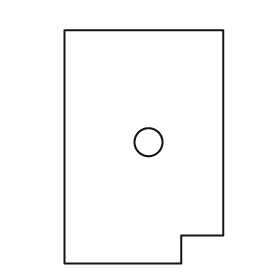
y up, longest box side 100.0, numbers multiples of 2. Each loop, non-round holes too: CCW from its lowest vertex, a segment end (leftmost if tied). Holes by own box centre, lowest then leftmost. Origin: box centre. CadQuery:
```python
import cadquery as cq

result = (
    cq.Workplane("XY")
    .moveTo(-34.0, -50.0)
    .lineTo(16.0, -50.0)
    .lineTo(16.0, -38.0)
    .lineTo(34.0, -38.0)
    .lineTo(34.0, 50.0)
    .lineTo(-34.0, 50.0)
    .close()
    .moveTo(2.0, 2.0)
    .circle(6.0)
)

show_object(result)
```